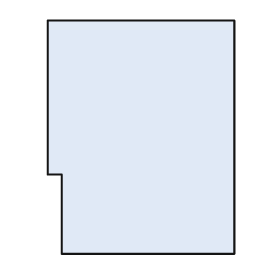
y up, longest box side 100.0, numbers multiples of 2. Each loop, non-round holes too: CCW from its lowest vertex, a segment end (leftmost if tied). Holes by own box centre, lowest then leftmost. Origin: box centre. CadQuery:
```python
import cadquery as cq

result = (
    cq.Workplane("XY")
    .moveTo(-34.0, -50.0)
    .lineTo(40.0, -50.0)
    .lineTo(40.0, 50.0)
    .lineTo(-40.0, 50.0)
    .lineTo(-40.0, -16.0)
    .lineTo(-34.0, -16.0)
    .close()
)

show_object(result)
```